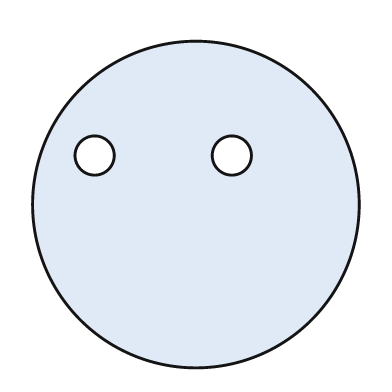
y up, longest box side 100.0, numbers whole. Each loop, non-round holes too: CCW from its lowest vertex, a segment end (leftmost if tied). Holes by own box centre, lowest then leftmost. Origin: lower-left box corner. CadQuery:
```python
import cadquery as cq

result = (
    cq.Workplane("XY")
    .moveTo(50.0, 50.0)
    .circle(50.0)
    .moveTo(19.0, 65.0)
    .circle(6.0)
    .moveTo(61.0, 65.0)
    .circle(6.0)
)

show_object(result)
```